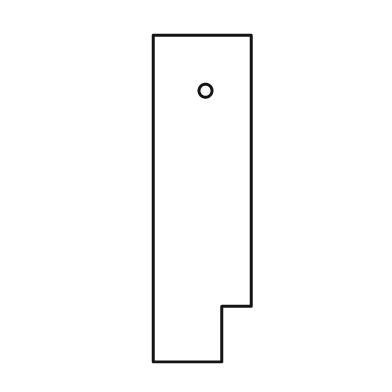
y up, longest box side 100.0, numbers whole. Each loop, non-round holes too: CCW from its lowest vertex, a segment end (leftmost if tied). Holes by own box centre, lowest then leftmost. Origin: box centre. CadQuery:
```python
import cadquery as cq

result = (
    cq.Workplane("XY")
    .moveTo(-15.0, -50.0)
    .lineTo(6.0, -50.0)
    .lineTo(6.0, -33.0)
    .lineTo(15.0, -33.0)
    .lineTo(15.0, 50.0)
    .lineTo(-15.0, 50.0)
    .close()
    .moveTo(1.0, 33.0)
    .circle(2.0)
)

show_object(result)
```